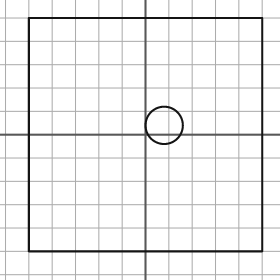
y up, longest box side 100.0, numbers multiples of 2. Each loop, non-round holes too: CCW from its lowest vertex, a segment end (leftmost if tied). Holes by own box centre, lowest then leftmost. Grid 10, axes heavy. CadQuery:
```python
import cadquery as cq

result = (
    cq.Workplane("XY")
    .moveTo(-50.0, -50.0)
    .lineTo(50.0, -50.0)
    .lineTo(50.0, 50.0)
    .lineTo(-50.0, 50.0)
    .close()
    .moveTo(8.0, 4.0)
    .circle(8.0)
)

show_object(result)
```